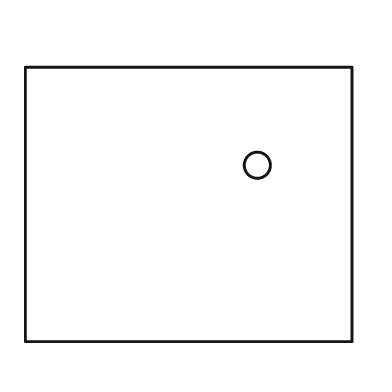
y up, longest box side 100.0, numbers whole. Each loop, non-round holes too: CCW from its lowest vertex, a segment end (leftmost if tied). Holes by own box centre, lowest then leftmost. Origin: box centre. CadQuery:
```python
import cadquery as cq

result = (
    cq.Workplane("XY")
    .moveTo(-50.0, -42.0)
    .lineTo(50.0, -42.0)
    .lineTo(50.0, 42.0)
    .lineTo(-50.0, 42.0)
    .close()
    .moveTo(21.0, 12.0)
    .circle(4.0)
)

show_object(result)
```